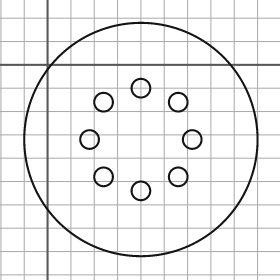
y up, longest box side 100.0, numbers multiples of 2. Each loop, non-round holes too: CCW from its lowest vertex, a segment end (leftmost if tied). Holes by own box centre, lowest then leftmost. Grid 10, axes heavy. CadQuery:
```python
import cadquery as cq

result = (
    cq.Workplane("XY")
    .moveTo(40.0, -32.0)
    .circle(50.0)
    .moveTo(40.0, -54.0)
    .circle(4.0)
    .moveTo(24.0, -48.0)
    .circle(4.0)
    .moveTo(56.0, -48.0)
    .circle(4.0)
    .moveTo(18.0, -32.0)
    .circle(4.0)
    .moveTo(62.0, -32.0)
    .circle(4.0)
    .moveTo(24.0, -16.0)
    .circle(4.0)
    .moveTo(56.0, -16.0)
    .circle(4.0)
    .moveTo(40.0, -10.0)
    .circle(4.0)
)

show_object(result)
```